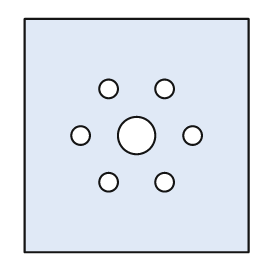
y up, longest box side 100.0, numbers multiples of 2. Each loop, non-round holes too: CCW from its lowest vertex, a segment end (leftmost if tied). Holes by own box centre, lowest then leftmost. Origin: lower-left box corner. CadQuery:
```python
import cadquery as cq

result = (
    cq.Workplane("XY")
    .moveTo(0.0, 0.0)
    .lineTo(96.0, 0.0)
    .lineTo(96.0, 100.0)
    .lineTo(0.0, 100.0)
    .close()
    .moveTo(36.0, 30.0)
    .circle(4.0)
    .moveTo(60.0, 30.0)
    .circle(4.0)
    .moveTo(24.0, 50.0)
    .circle(4.0)
    .moveTo(48.0, 50.0)
    .circle(8.0)
    .moveTo(72.0, 50.0)
    .circle(4.0)
    .moveTo(36.0, 70.0)
    .circle(4.0)
    .moveTo(60.0, 70.0)
    .circle(4.0)
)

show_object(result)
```